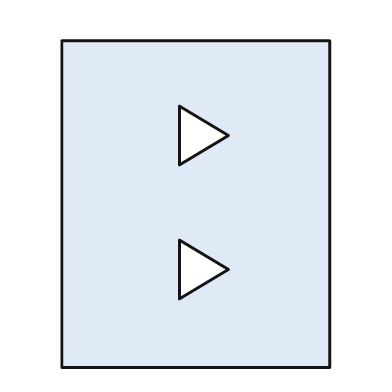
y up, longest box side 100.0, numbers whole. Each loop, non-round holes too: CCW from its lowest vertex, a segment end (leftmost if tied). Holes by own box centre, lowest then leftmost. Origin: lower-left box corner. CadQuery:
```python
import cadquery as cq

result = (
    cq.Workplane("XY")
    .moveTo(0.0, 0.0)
    .lineTo(82.0, 0.0)
    .lineTo(82.0, 100.0)
    .lineTo(0.0, 100.0)
    .close()
    .moveTo(36.0, 21.0)
    .lineTo(51.0, 30.0)
    .lineTo(36.0, 39.0)
    .close()
    .moveTo(36.0, 62.0)
    .lineTo(51.0, 71.0)
    .lineTo(36.0, 80.0)
    .close()
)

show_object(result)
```